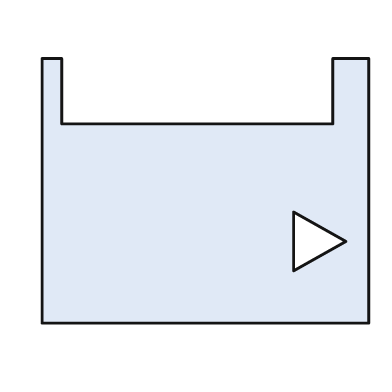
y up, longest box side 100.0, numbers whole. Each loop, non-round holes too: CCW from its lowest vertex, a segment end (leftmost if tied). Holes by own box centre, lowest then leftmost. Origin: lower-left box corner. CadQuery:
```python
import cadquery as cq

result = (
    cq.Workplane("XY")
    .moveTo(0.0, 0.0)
    .lineTo(100.0, 0.0)
    .lineTo(100.0, 81.0)
    .lineTo(89.0, 81.0)
    .lineTo(89.0, 61.0)
    .lineTo(6.0, 61.0)
    .lineTo(6.0, 81.0)
    .lineTo(0.0, 81.0)
    .close()
    .moveTo(77.0, 16.0)
    .lineTo(93.0, 25.0)
    .lineTo(77.0, 34.0)
    .close()
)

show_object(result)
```